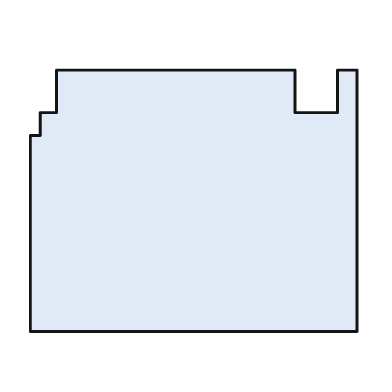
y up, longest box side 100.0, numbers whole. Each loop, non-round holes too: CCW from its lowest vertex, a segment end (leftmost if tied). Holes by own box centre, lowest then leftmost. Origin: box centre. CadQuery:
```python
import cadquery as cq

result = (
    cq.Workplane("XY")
    .moveTo(-50.0, -40.0)
    .lineTo(50.0, -40.0)
    .lineTo(50.0, 40.0)
    .lineTo(44.0, 40.0)
    .lineTo(44.0, 27.0)
    .lineTo(31.0, 27.0)
    .lineTo(31.0, 40.0)
    .lineTo(-42.0, 40.0)
    .lineTo(-42.0, 27.0)
    .lineTo(-47.0, 27.0)
    .lineTo(-47.0, 20.0)
    .lineTo(-50.0, 20.0)
    .close()
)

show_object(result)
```